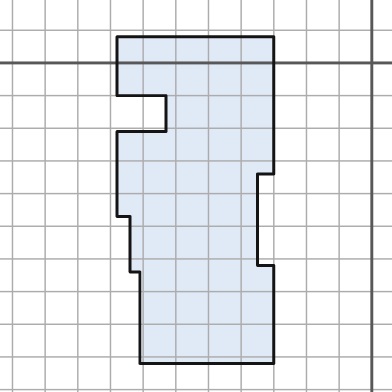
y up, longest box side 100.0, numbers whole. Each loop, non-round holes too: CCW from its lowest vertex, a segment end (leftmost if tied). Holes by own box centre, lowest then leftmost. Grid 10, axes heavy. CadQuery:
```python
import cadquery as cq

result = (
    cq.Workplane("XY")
    .moveTo(-71.0, -92.0)
    .lineTo(-30.0, -92.0)
    .lineTo(-30.0, -62.0)
    .lineTo(-35.0, -62.0)
    .lineTo(-35.0, -34.0)
    .lineTo(-30.0, -34.0)
    .lineTo(-30.0, 8.0)
    .lineTo(-78.0, 8.0)
    .lineTo(-78.0, -10.0)
    .lineTo(-63.0, -10.0)
    .lineTo(-63.0, -21.0)
    .lineTo(-78.0, -21.0)
    .lineTo(-78.0, -47.0)
    .lineTo(-74.0, -47.0)
    .lineTo(-74.0, -64.0)
    .lineTo(-71.0, -64.0)
    .close()
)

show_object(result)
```